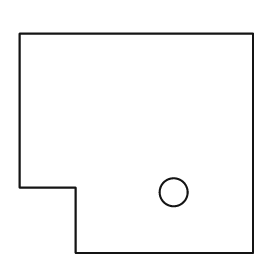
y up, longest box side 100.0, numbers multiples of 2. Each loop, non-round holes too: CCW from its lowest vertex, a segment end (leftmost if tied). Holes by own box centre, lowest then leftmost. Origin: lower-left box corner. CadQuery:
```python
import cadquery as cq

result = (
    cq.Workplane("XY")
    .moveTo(24.0, 0.0)
    .lineTo(100.0, 0.0)
    .lineTo(100.0, 94.0)
    .lineTo(0.0, 94.0)
    .lineTo(0.0, 28.0)
    .lineTo(24.0, 28.0)
    .close()
    .moveTo(66.0, 26.0)
    .circle(6.0)
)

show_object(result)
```